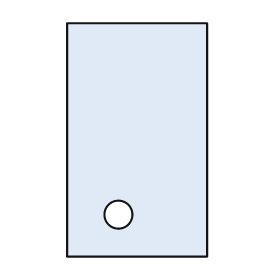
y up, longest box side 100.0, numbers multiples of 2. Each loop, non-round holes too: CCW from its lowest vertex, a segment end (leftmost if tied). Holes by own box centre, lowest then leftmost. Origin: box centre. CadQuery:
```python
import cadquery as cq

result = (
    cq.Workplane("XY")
    .moveTo(-30.0, -50.0)
    .lineTo(30.0, -50.0)
    .lineTo(30.0, 50.0)
    .lineTo(-30.0, 50.0)
    .close()
    .moveTo(-8.0, -32.0)
    .circle(6.0)
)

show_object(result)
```